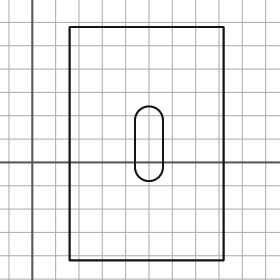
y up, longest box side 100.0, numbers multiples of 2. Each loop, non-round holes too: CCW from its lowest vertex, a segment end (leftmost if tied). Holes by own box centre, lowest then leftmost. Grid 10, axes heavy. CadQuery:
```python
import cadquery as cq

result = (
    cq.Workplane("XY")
    .moveTo(16.0, -42.0)
    .lineTo(82.0, -42.0)
    .lineTo(82.0, 58.0)
    .lineTo(16.0, 58.0)
    .close()
    .moveTo(44.0, -2.0)
    .threePointArc((50.0, -8.0), (56.0, -2.0))
    .lineTo(56.0, 18.0)
    .threePointArc((50.0, 24.0), (44.0, 18.0))
    .close()
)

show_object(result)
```